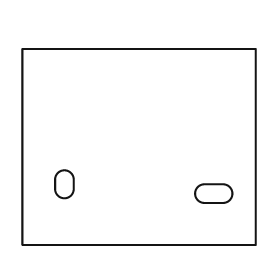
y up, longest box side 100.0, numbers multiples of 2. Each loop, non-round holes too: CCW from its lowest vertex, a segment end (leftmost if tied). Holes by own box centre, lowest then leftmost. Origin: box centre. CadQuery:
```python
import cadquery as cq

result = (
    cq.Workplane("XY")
    .moveTo(-50.0, -42.0)
    .lineTo(50.0, -42.0)
    .lineTo(50.0, 42.0)
    .lineTo(-50.0, 42.0)
    .close()
    .moveTo(28.0, -24.0)
    .lineTo(36.0, -24.0)
    .threePointArc((40.0, -20.0), (36.0, -16.0))
    .lineTo(28.0, -16.0)
    .threePointArc((24.0, -20.0), (28.0, -24.0))
    .close()
    .moveTo(-36.0, -18.0)
    .threePointArc((-32.0, -22.0), (-28.0, -18.0))
    .lineTo(-28.0, -14.0)
    .threePointArc((-32.0, -10.0), (-36.0, -14.0))
    .close()
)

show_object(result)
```